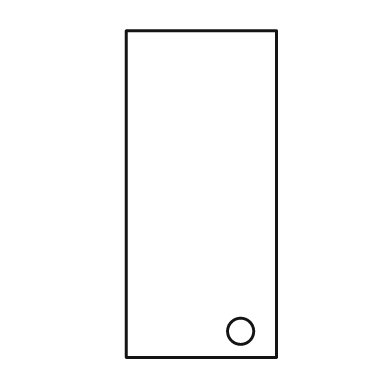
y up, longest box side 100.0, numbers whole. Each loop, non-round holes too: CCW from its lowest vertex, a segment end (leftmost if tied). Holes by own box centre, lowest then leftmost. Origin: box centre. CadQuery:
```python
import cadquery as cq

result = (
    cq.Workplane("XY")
    .moveTo(-23.0, -50.0)
    .lineTo(23.0, -50.0)
    .lineTo(23.0, 50.0)
    .lineTo(-23.0, 50.0)
    .close()
    .moveTo(12.0, -42.0)
    .circle(4.0)
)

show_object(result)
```